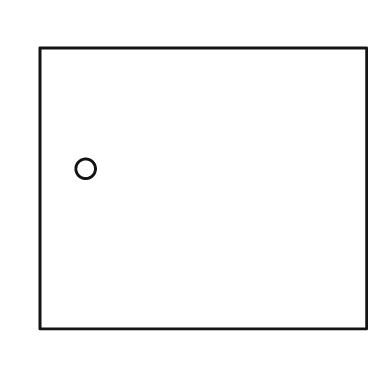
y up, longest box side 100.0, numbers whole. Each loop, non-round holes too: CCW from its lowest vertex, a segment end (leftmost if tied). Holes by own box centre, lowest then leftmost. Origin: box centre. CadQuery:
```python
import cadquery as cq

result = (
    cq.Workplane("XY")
    .moveTo(-50.0, -43.0)
    .lineTo(50.0, -43.0)
    .lineTo(50.0, 43.0)
    .lineTo(-50.0, 43.0)
    .close()
    .moveTo(-36.0, 6.0)
    .circle(3.0)
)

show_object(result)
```